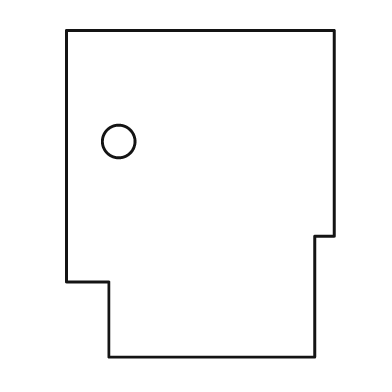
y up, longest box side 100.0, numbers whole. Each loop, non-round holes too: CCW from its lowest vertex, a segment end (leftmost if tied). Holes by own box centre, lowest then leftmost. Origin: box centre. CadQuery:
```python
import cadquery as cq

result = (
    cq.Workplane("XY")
    .moveTo(-28.0, -50.0)
    .lineTo(35.0, -50.0)
    .lineTo(35.0, -13.0)
    .lineTo(41.0, -13.0)
    .lineTo(41.0, 50.0)
    .lineTo(-41.0, 50.0)
    .lineTo(-41.0, -27.0)
    .lineTo(-28.0, -27.0)
    .close()
    .moveTo(-25.0, 16.0)
    .circle(5.0)
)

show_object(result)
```